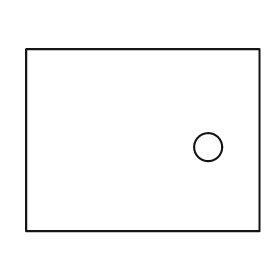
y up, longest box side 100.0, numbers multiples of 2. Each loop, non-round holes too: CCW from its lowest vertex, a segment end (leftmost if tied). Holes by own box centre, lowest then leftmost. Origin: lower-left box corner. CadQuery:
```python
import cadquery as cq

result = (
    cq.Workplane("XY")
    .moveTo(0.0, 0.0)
    .lineTo(100.0, 0.0)
    .lineTo(100.0, 78.0)
    .lineTo(0.0, 78.0)
    .close()
    .moveTo(78.0, 36.0)
    .circle(6.0)
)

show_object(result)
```